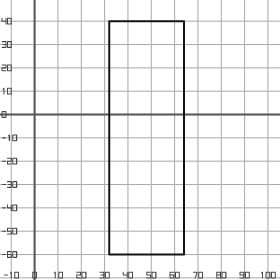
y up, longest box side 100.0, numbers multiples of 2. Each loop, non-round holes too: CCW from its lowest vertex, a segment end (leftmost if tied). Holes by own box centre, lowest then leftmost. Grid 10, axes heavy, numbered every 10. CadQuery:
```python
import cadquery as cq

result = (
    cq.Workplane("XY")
    .moveTo(32.0, -60.0)
    .lineTo(64.0, -60.0)
    .lineTo(64.0, 40.0)
    .lineTo(32.0, 40.0)
    .close()
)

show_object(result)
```